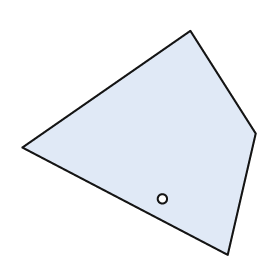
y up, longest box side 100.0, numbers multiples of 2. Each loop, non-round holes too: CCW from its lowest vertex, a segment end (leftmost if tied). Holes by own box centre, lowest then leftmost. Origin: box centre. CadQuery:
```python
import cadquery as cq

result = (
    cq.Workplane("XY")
    .moveTo(38.0, -48.0)
    .lineTo(50.0, 4.0)
    .lineTo(22.0, 48.0)
    .lineTo(-50.0, -2.0)
    .close()
    .moveTo(10.0, -24.0)
    .circle(2.0)
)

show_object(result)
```